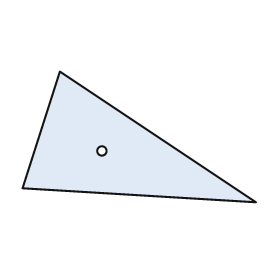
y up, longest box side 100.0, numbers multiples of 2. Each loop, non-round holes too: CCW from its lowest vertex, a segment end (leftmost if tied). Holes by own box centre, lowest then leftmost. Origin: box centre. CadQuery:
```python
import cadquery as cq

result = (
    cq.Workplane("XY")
    .moveTo(50.0, -28.0)
    .lineTo(-34.0, 28.0)
    .lineTo(-50.0, -22.0)
    .close()
    .moveTo(-16.0, -6.0)
    .circle(2.0)
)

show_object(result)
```